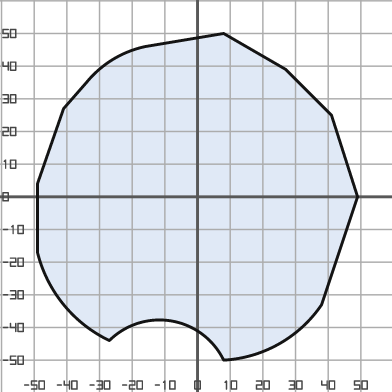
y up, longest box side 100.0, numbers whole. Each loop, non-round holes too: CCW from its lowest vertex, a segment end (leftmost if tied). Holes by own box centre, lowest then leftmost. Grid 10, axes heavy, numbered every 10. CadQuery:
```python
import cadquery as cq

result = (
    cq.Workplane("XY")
    .moveTo(8.0, -50.0)
    .threePointArc((25.0, -45.0), (38.0, -33.0))
    .lineTo(49.0, 0.0)
    .lineTo(41.0, 25.0)
    .lineTo(27.0, 39.0)
    .lineTo(8.0, 50.0)
    .lineTo(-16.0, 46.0)
    .threePointArc((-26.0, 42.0), (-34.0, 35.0))
    .lineTo(-41.0, 27.0)
    .lineTo(-49.0, 4.0)
    .lineTo(-49.0, -17.0)
    .threePointArc((-41.0, -33.0), (-27.0, -44.0))
    .threePointArc((-8.0, -38.0), (8.0, -50.0))
    .close()
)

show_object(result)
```